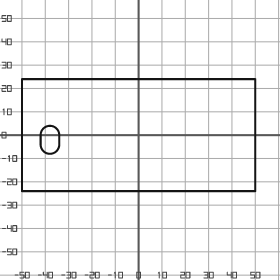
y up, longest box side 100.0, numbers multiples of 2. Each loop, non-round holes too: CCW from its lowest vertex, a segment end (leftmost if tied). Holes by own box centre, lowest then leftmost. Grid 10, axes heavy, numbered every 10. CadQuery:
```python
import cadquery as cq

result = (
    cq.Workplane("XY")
    .moveTo(-50.0, -24.0)
    .lineTo(50.0, -24.0)
    .lineTo(50.0, 24.0)
    .lineTo(-50.0, 24.0)
    .close()
    .moveTo(-42.0, -4.0)
    .threePointArc((-38.0, -8.0), (-34.0, -4.0))
    .lineTo(-34.0, 0.0)
    .threePointArc((-38.0, 4.0), (-42.0, 0.0))
    .close()
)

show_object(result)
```